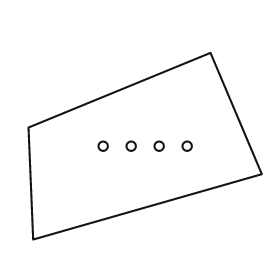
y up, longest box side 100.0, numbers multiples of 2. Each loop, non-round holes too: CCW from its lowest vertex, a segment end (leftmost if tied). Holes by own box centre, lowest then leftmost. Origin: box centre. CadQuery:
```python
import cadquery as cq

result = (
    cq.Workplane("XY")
    .moveTo(-48.0, -40.0)
    .lineTo(50.0, -12.0)
    .lineTo(28.0, 40.0)
    .lineTo(-50.0, 8.0)
    .close()
    .moveTo(-18.0, 0.0)
    .circle(2.0)
    .moveTo(-6.0, 0.0)
    .circle(2.0)
    .moveTo(6.0, 0.0)
    .circle(2.0)
    .moveTo(18.0, 0.0)
    .circle(2.0)
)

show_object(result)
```